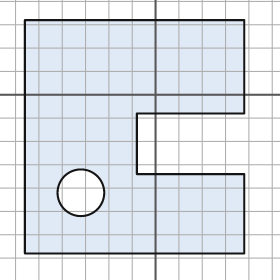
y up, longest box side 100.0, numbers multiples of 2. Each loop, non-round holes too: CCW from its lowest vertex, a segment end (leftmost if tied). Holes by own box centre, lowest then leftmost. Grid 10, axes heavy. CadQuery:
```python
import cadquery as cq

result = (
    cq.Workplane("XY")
    .moveTo(-56.0, -68.0)
    .lineTo(38.0, -68.0)
    .lineTo(38.0, -34.0)
    .lineTo(-8.0, -34.0)
    .lineTo(-8.0, -8.0)
    .lineTo(38.0, -8.0)
    .lineTo(38.0, 32.0)
    .lineTo(-56.0, 32.0)
    .close()
    .moveTo(-32.0, -42.0)
    .circle(10.0)
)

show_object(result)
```